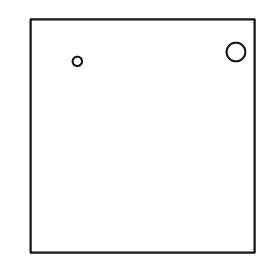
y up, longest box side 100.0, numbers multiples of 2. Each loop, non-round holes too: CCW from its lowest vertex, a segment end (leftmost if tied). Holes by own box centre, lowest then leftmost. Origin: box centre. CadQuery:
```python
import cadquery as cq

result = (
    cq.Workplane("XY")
    .moveTo(-48.0, -50.0)
    .lineTo(48.0, -50.0)
    .lineTo(48.0, 50.0)
    .lineTo(-48.0, 50.0)
    .close()
    .moveTo(-28.0, 32.0)
    .circle(2.0)
    .moveTo(40.0, 36.0)
    .circle(4.0)
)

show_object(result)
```